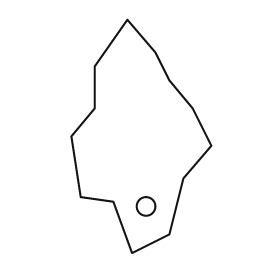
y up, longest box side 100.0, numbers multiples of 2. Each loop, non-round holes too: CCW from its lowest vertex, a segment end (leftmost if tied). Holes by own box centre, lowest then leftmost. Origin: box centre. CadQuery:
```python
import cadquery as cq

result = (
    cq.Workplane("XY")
    .moveTo(-4.0, -50.0)
    .lineTo(12.0, -42.0)
    .lineTo(18.0, -18.0)
    .lineTo(30.0, -4.0)
    .lineTo(22.0, 12.0)
    .lineTo(12.0, 24.0)
    .lineTo(6.0, 36.0)
    .lineTo(-6.0, 50.0)
    .lineTo(-20.0, 30.0)
    .lineTo(-20.0, 12.0)
    .lineTo(-30.0, 0.0)
    .lineTo(-26.0, -26.0)
    .lineTo(-12.0, -28.0)
    .close()
    .moveTo(2.0, -30.0)
    .circle(4.0)
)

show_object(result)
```